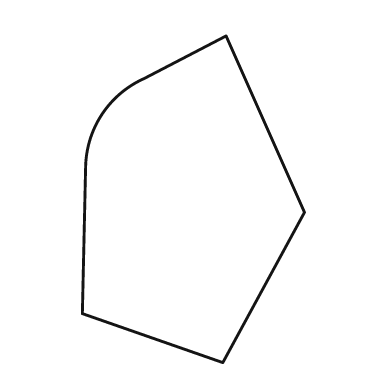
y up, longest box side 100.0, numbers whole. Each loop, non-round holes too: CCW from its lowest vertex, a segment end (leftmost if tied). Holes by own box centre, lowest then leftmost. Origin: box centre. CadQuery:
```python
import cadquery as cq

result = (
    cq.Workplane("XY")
    .moveTo(9.0, -50.0)
    .lineTo(34.0, -4.0)
    .lineTo(10.0, 50.0)
    .lineTo(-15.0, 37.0)
    .threePointArc((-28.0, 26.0), (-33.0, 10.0))
    .lineTo(-34.0, -35.0)
    .close()
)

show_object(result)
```